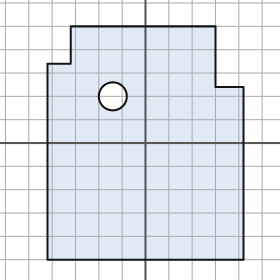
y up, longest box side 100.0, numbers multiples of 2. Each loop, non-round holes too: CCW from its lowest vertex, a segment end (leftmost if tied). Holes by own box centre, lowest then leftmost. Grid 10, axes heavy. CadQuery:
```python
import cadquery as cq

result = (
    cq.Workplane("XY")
    .moveTo(-42.0, -50.0)
    .lineTo(42.0, -50.0)
    .lineTo(42.0, 24.0)
    .lineTo(30.0, 24.0)
    .lineTo(30.0, 50.0)
    .lineTo(-32.0, 50.0)
    .lineTo(-32.0, 34.0)
    .lineTo(-42.0, 34.0)
    .close()
    .moveTo(-14.0, 20.0)
    .circle(6.0)
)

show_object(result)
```